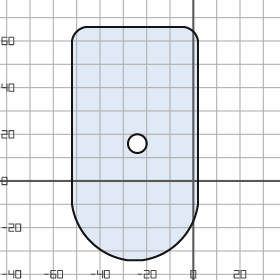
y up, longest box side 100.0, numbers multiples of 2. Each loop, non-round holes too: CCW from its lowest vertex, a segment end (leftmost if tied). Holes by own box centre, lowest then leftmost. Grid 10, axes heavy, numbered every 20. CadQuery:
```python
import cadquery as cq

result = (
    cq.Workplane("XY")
    .moveTo(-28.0, -34.0)
    .lineTo(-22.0, -34.0)
    .threePointArc((-6.0, -26.0), (2.0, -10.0))
    .lineTo(2.0, 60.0)
    .threePointArc((0.0, 64.0), (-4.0, 66.0))
    .lineTo(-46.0, 66.0)
    .threePointArc((-50.0, 64.0), (-52.0, 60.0))
    .lineTo(-52.0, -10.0)
    .threePointArc((-44.0, -26.0), (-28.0, -34.0))
    .close()
    .moveTo(-24.0, 16.0)
    .circle(4.0)
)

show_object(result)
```